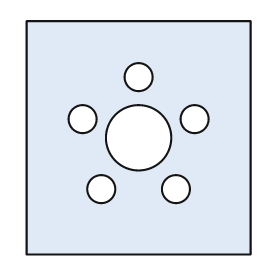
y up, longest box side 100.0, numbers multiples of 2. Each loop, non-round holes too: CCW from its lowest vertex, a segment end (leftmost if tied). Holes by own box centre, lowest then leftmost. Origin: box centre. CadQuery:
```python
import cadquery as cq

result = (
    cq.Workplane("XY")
    .moveTo(-48.0, -50.0)
    .lineTo(48.0, -50.0)
    .lineTo(48.0, 50.0)
    .lineTo(-48.0, 50.0)
    .close()
    .moveTo(-16.0, -22.0)
    .circle(6.0)
    .moveTo(16.0, -22.0)
    .circle(6.0)
    .moveTo(0.0, 0.0)
    .circle(14.0)
    .moveTo(-24.0, 8.0)
    .circle(6.0)
    .moveTo(24.0, 8.0)
    .circle(6.0)
    .moveTo(0.0, 26.0)
    .circle(6.0)
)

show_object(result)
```